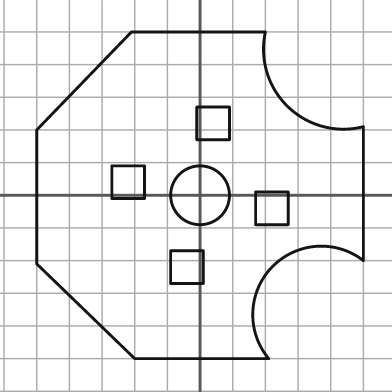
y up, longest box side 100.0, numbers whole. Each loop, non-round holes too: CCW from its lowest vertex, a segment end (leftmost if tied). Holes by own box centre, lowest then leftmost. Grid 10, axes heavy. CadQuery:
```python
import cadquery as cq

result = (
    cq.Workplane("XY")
    .moveTo(-20.0, -50.0)
    .lineTo(21.0, -50.0)
    .threePointArc((22.0, -22.0), (50.0, -20.0))
    .lineTo(50.0, 21.0)
    .threePointArc((27.0, 27.0), (20.0, 50.0))
    .lineTo(-21.0, 50.0)
    .lineTo(-50.0, 20.0)
    .lineTo(-50.0, -21.0)
    .close()
    .moveTo(-9.0, -27.0)
    .lineTo(1.0, -27.0)
    .lineTo(1.0, -17.0)
    .lineTo(-9.0, -17.0)
    .close()
    .moveTo(17.0, -9.0)
    .lineTo(27.0, -9.0)
    .lineTo(27.0, 1.0)
    .lineTo(17.0, 1.0)
    .close()
    .moveTo(0.0, 0.0)
    .circle(9.0)
    .moveTo(-27.0, -1.0)
    .lineTo(-17.0, -1.0)
    .lineTo(-17.0, 9.0)
    .lineTo(-27.0, 9.0)
    .close()
    .moveTo(-1.0, 17.0)
    .lineTo(9.0, 17.0)
    .lineTo(9.0, 27.0)
    .lineTo(-1.0, 27.0)
    .close()
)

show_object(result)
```